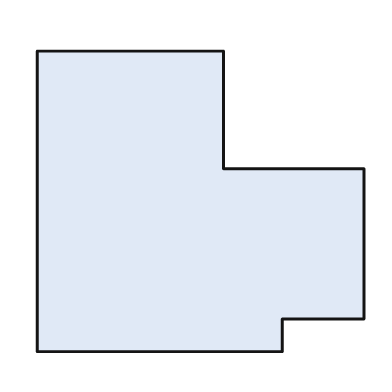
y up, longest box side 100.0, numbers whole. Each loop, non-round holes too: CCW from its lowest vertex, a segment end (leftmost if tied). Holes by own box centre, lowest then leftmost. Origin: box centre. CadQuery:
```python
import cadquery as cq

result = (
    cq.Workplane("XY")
    .moveTo(-50.0, -46.0)
    .lineTo(25.0, -46.0)
    .lineTo(25.0, -36.0)
    .lineTo(50.0, -36.0)
    .lineTo(50.0, 10.0)
    .lineTo(7.0, 10.0)
    .lineTo(7.0, 46.0)
    .lineTo(-50.0, 46.0)
    .close()
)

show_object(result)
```